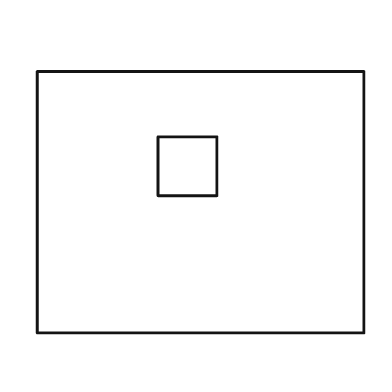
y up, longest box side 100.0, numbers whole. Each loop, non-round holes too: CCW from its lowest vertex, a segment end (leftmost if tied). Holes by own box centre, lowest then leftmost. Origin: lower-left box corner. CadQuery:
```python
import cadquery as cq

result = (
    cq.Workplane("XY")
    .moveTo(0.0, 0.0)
    .lineTo(100.0, 0.0)
    .lineTo(100.0, 80.0)
    .lineTo(0.0, 80.0)
    .close()
    .moveTo(37.0, 42.0)
    .lineTo(55.0, 42.0)
    .lineTo(55.0, 60.0)
    .lineTo(37.0, 60.0)
    .close()
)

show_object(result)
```